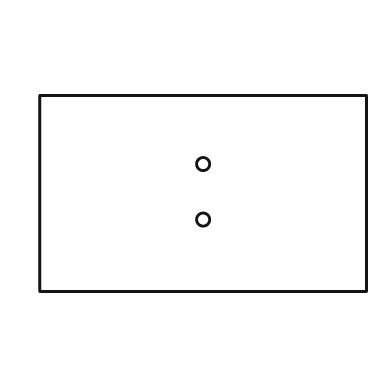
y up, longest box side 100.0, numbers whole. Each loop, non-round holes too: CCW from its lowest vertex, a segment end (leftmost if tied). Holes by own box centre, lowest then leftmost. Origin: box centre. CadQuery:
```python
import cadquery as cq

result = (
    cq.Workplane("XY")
    .moveTo(-50.0, -30.0)
    .lineTo(50.0, -30.0)
    .lineTo(50.0, 30.0)
    .lineTo(-50.0, 30.0)
    .close()
    .moveTo(0.0, -8.0)
    .circle(2.0)
    .moveTo(0.0, 9.0)
    .circle(2.0)
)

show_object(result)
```